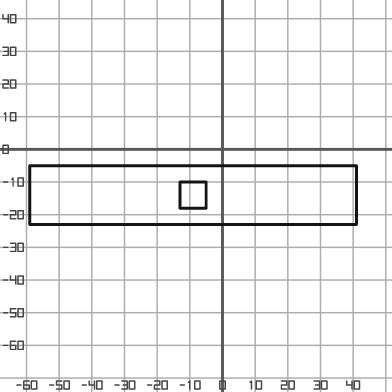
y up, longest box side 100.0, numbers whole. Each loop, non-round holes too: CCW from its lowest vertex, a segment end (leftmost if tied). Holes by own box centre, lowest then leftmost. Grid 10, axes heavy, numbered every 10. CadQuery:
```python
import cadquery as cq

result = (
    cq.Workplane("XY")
    .moveTo(-59.0, -23.0)
    .lineTo(41.0, -23.0)
    .lineTo(41.0, -5.0)
    .lineTo(-59.0, -5.0)
    .close()
    .moveTo(-13.0, -18.0)
    .lineTo(-5.0, -18.0)
    .lineTo(-5.0, -10.0)
    .lineTo(-13.0, -10.0)
    .close()
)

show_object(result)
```